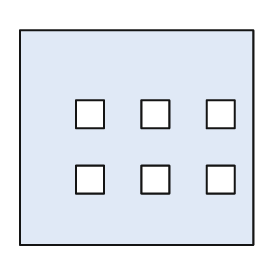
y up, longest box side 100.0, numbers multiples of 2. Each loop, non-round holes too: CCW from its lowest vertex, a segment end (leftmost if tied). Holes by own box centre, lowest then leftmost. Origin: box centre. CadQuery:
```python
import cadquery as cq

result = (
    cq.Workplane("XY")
    .moveTo(-50.0, -46.0)
    .lineTo(50.0, -46.0)
    .lineTo(50.0, 46.0)
    .lineTo(-50.0, 46.0)
    .close()
    .moveTo(-26.0, -24.0)
    .lineTo(-14.0, -24.0)
    .lineTo(-14.0, -12.0)
    .lineTo(-26.0, -12.0)
    .close()
    .moveTo(2.0, -24.0)
    .lineTo(14.0, -24.0)
    .lineTo(14.0, -12.0)
    .lineTo(2.0, -12.0)
    .close()
    .moveTo(30.0, -24.0)
    .lineTo(42.0, -24.0)
    .lineTo(42.0, -12.0)
    .lineTo(30.0, -12.0)
    .close()
    .moveTo(-26.0, 4.0)
    .lineTo(-14.0, 4.0)
    .lineTo(-14.0, 16.0)
    .lineTo(-26.0, 16.0)
    .close()
    .moveTo(2.0, 4.0)
    .lineTo(14.0, 4.0)
    .lineTo(14.0, 16.0)
    .lineTo(2.0, 16.0)
    .close()
    .moveTo(30.0, 4.0)
    .lineTo(42.0, 4.0)
    .lineTo(42.0, 16.0)
    .lineTo(30.0, 16.0)
    .close()
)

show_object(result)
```